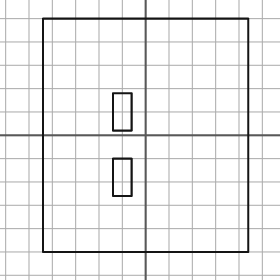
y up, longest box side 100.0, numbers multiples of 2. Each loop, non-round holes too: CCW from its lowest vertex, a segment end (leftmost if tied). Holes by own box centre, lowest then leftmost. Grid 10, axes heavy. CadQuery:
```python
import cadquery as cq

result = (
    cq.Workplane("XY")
    .moveTo(-44.0, -50.0)
    .lineTo(44.0, -50.0)
    .lineTo(44.0, 50.0)
    .lineTo(-44.0, 50.0)
    .close()
    .moveTo(-14.0, -26.0)
    .lineTo(-6.0, -26.0)
    .lineTo(-6.0, -10.0)
    .lineTo(-14.0, -10.0)
    .close()
    .moveTo(-14.0, 2.0)
    .lineTo(-6.0, 2.0)
    .lineTo(-6.0, 18.0)
    .lineTo(-14.0, 18.0)
    .close()
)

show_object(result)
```